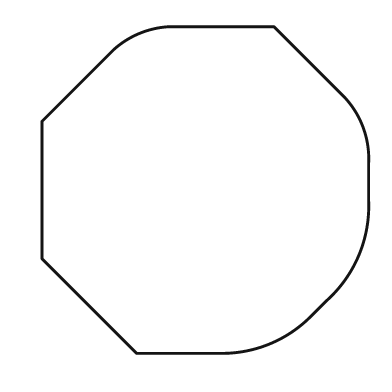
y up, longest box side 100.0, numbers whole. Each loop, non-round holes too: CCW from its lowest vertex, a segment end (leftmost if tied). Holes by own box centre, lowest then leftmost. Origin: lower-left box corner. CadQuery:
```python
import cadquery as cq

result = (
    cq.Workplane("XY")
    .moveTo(29.0, 0.0)
    .lineTo(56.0, 0.0)
    .threePointArc((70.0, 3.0), (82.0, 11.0))
    .lineTo(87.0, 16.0)
    .threePointArc((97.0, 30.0), (100.0, 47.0))
    .lineTo(100.0, 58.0)
    .threePointArc((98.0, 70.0), (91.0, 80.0))
    .lineTo(71.0, 100.0)
    .lineTo(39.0, 100.0)
    .threePointArc((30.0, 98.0), (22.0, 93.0))
    .lineTo(0.0, 71.0)
    .lineTo(0.0, 29.0)
    .close()
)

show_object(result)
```